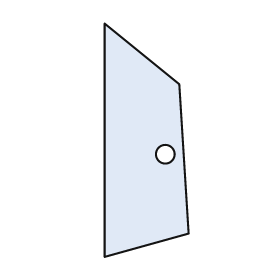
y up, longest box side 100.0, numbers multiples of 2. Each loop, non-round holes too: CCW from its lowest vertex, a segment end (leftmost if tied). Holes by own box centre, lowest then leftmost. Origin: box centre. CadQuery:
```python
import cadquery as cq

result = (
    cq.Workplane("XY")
    .moveTo(-18.0, -50.0)
    .lineTo(18.0, -40.0)
    .lineTo(14.0, 24.0)
    .lineTo(-18.0, 50.0)
    .close()
    .moveTo(8.0, -6.0)
    .circle(4.0)
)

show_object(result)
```